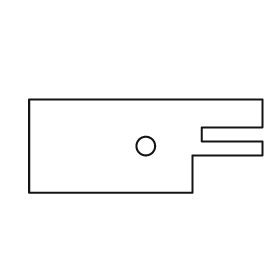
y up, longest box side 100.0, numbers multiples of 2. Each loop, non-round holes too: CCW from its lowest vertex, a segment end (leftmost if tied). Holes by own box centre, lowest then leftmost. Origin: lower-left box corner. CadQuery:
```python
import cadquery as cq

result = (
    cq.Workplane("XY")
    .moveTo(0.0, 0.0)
    .lineTo(70.0, 0.0)
    .lineTo(70.0, 16.0)
    .lineTo(100.0, 16.0)
    .lineTo(100.0, 22.0)
    .lineTo(74.0, 22.0)
    .lineTo(74.0, 28.0)
    .lineTo(100.0, 28.0)
    .lineTo(100.0, 40.0)
    .lineTo(0.0, 40.0)
    .close()
    .moveTo(50.0, 20.0)
    .circle(4.0)
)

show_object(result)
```